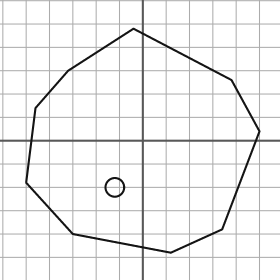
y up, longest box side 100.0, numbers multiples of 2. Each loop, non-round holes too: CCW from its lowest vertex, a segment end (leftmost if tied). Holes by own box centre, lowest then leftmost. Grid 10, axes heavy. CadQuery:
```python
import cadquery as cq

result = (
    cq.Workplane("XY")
    .moveTo(12.0, -48.0)
    .lineTo(34.0, -38.0)
    .lineTo(50.0, 4.0)
    .lineTo(38.0, 26.0)
    .lineTo(-4.0, 48.0)
    .lineTo(-32.0, 30.0)
    .lineTo(-46.0, 14.0)
    .lineTo(-50.0, -18.0)
    .lineTo(-30.0, -40.0)
    .close()
    .moveTo(-12.0, -20.0)
    .circle(4.0)
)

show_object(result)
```